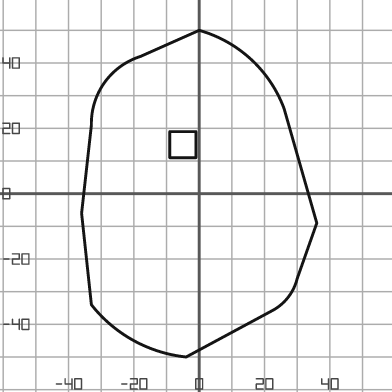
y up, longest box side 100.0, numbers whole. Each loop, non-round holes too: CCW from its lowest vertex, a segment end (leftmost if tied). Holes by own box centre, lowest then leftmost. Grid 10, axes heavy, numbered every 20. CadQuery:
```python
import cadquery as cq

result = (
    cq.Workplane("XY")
    .moveTo(-4.0, -50.0)
    .lineTo(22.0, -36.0)
    .threePointArc((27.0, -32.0), (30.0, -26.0))
    .lineTo(36.0, -9.0)
    .lineTo(26.0, 26.0)
    .threePointArc((16.0, 41.0), (0.0, 50.0))
    .lineTo(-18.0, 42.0)
    .threePointArc((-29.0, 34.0), (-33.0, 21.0))
    .lineTo(-36.0, -6.0)
    .lineTo(-33.0, -34.0)
    .threePointArc((-20.0, -45.0), (-4.0, -50.0))
    .close()
    .moveTo(-9.0, 11.0)
    .lineTo(-1.0, 11.0)
    .lineTo(-1.0, 19.0)
    .lineTo(-9.0, 19.0)
    .close()
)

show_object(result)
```